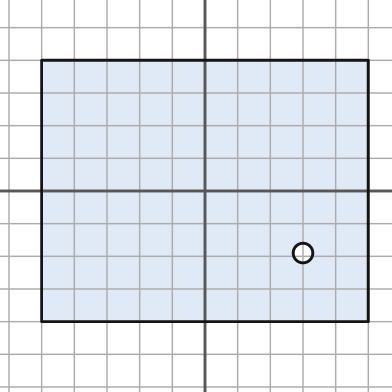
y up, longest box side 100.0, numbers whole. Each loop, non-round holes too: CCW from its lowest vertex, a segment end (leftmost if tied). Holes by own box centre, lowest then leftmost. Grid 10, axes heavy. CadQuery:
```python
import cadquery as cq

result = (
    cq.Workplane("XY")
    .moveTo(-50.0, -40.0)
    .lineTo(50.0, -40.0)
    .lineTo(50.0, 40.0)
    .lineTo(-50.0, 40.0)
    .close()
    .moveTo(30.0, -19.0)
    .circle(3.0)
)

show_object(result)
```